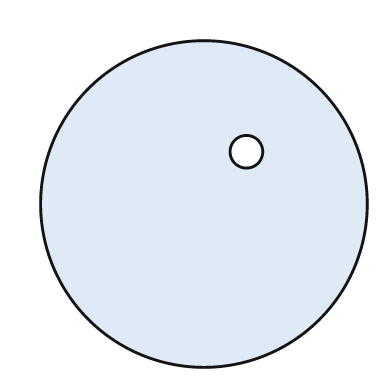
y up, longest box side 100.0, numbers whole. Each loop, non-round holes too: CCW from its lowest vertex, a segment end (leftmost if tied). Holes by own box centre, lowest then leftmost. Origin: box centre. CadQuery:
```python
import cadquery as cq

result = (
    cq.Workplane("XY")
    .moveTo(0.0, 0.0)
    .circle(50.0)
    .moveTo(13.0, 16.0)
    .circle(5.0)
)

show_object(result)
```